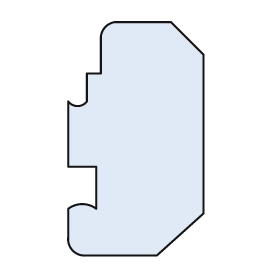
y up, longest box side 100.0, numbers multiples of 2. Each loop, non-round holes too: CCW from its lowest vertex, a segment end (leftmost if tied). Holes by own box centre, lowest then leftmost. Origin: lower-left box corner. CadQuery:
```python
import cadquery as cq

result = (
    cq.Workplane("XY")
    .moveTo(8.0, 0.0)
    .lineTo(38.0, 0.0)
    .lineTo(58.0, 18.0)
    .lineTo(58.0, 86.0)
    .lineTo(44.0, 100.0)
    .lineTo(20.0, 100.0)
    .threePointArc((16.0, 98.0), (14.0, 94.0))
    .lineTo(14.0, 78.0)
    .lineTo(8.0, 78.0)
    .lineTo(8.0, 66.0)
    .threePointArc((4.0, 64.0), (0.0, 66.0))
    .lineTo(0.0, 38.0)
    .lineTo(12.0, 38.0)
    .lineTo(12.0, 20.0)
    .threePointArc((6.0, 22.0), (0.0, 20.0))
    .lineTo(0.0, 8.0)
    .threePointArc((2.0, 2.0), (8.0, 0.0))
    .close()
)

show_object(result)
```